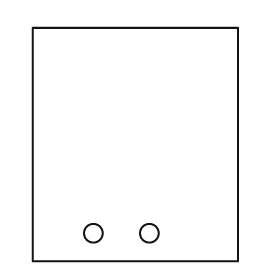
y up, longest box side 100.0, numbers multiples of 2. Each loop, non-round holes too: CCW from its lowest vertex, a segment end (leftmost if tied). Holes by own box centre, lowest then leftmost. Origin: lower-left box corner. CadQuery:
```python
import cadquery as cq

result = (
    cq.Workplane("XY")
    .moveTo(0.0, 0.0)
    .lineTo(88.0, 0.0)
    .lineTo(88.0, 100.0)
    .lineTo(0.0, 100.0)
    .close()
    .moveTo(26.0, 12.0)
    .circle(4.0)
    .moveTo(50.0, 12.0)
    .circle(4.0)
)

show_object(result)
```